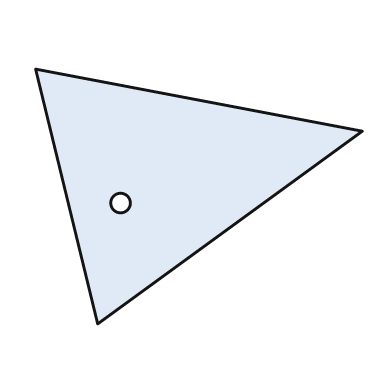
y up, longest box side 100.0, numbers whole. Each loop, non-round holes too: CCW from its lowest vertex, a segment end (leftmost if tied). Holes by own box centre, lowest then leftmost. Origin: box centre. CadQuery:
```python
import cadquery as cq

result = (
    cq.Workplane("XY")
    .moveTo(-31.0, -39.0)
    .lineTo(50.0, 20.0)
    .lineTo(-50.0, 39.0)
    .close()
    .moveTo(-24.0, -2.0)
    .circle(3.0)
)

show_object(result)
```